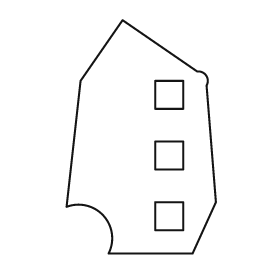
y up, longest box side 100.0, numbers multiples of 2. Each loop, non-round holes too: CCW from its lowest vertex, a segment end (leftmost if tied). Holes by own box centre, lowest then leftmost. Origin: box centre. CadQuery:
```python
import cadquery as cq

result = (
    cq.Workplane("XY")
    .moveTo(-14.0, -50.0)
    .lineTo(22.0, -50.0)
    .lineTo(32.0, -28.0)
    .lineTo(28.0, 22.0)
    .threePointArc((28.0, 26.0), (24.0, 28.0))
    .lineTo(-8.0, 50.0)
    .lineTo(-26.0, 24.0)
    .lineTo(-32.0, -30.0)
    .threePointArc((-16.0, -34.0), (-14.0, -50.0))
    .close()
    .moveTo(6.0, -40.0)
    .lineTo(18.0, -40.0)
    .lineTo(18.0, -28.0)
    .lineTo(6.0, -28.0)
    .close()
    .moveTo(6.0, -14.0)
    .lineTo(18.0, -14.0)
    .lineTo(18.0, -2.0)
    .lineTo(6.0, -2.0)
    .close()
    .moveTo(6.0, 12.0)
    .lineTo(18.0, 12.0)
    .lineTo(18.0, 24.0)
    .lineTo(6.0, 24.0)
    .close()
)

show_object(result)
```